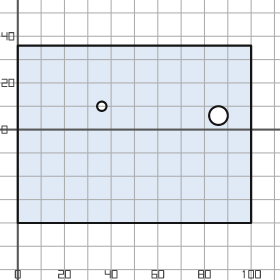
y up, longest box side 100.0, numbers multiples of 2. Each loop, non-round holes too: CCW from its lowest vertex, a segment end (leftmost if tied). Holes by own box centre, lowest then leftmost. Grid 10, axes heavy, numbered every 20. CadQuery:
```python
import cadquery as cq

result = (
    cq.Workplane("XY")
    .moveTo(0.0, -40.0)
    .lineTo(100.0, -40.0)
    .lineTo(100.0, 36.0)
    .lineTo(0.0, 36.0)
    .close()
    .moveTo(86.0, 6.0)
    .circle(4.0)
    .moveTo(36.0, 10.0)
    .circle(2.0)
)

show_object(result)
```